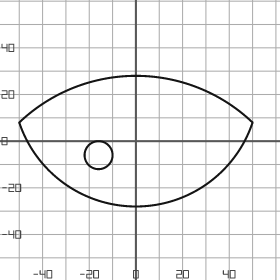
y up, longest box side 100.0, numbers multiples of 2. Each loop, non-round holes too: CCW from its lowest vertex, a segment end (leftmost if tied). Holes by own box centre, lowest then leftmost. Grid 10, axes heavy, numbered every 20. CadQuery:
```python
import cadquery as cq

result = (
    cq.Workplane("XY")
    .moveTo(-50.0, 8.0)
    .threePointArc((0.0, -28.0), (50.0, 8.0))
    .threePointArc((0.0, 28.0), (-50.0, 8.0))
    .close()
    .moveTo(-16.0, -6.0)
    .circle(6.0)
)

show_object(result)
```